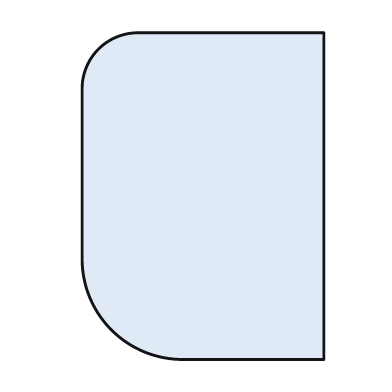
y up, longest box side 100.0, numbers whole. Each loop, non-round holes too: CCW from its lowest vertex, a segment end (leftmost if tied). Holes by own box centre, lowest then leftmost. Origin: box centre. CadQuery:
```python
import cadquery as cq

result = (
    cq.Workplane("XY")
    .moveTo(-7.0, -50.0)
    .lineTo(37.0, -50.0)
    .lineTo(37.0, 50.0)
    .lineTo(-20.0, 50.0)
    .threePointArc((-32.0, 45.0), (-37.0, 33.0))
    .lineTo(-37.0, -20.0)
    .threePointArc((-28.0, -41.0), (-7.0, -50.0))
    .close()
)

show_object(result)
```